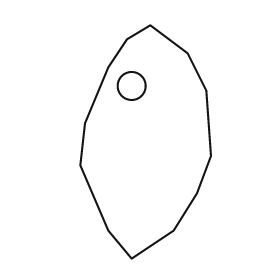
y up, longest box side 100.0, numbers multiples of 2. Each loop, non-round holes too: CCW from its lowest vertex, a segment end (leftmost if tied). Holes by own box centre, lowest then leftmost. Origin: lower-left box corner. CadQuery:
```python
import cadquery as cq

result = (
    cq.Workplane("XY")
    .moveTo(22.0, 0.0)
    .lineTo(40.0, 12.0)
    .lineTo(50.0, 28.0)
    .lineTo(56.0, 44.0)
    .lineTo(54.0, 72.0)
    .lineTo(46.0, 88.0)
    .lineTo(30.0, 100.0)
    .lineTo(20.0, 94.0)
    .lineTo(12.0, 82.0)
    .lineTo(2.0, 58.0)
    .lineTo(0.0, 40.0)
    .lineTo(12.0, 12.0)
    .close()
    .moveTo(22.0, 74.0)
    .circle(6.0)
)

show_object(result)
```